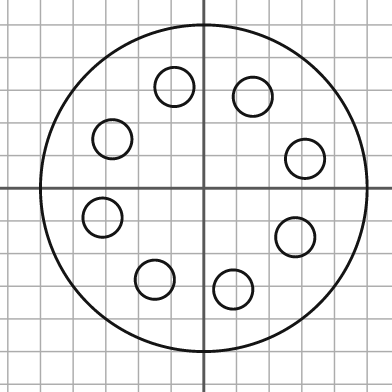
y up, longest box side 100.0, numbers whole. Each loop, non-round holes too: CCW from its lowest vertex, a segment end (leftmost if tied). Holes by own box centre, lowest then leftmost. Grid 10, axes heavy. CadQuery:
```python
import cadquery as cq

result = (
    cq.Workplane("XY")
    .moveTo(0.0, 0.0)
    .circle(50.0)
    .moveTo(9.0, -31.0)
    .circle(6.0)
    .moveTo(-15.0, -28.0)
    .circle(6.0)
    .moveTo(28.0, -15.0)
    .circle(6.0)
    .moveTo(-31.0, -9.0)
    .circle(6.0)
    .moveTo(31.0, 9.0)
    .circle(6.0)
    .moveTo(-28.0, 15.0)
    .circle(6.0)
    .moveTo(15.0, 28.0)
    .circle(6.0)
    .moveTo(-9.0, 31.0)
    .circle(6.0)
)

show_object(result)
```